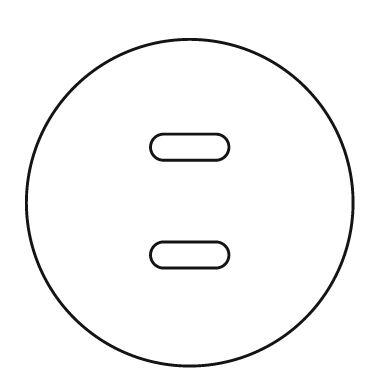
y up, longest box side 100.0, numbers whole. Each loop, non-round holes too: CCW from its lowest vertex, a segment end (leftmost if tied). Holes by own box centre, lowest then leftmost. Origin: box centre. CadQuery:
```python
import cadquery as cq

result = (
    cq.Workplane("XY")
    .moveTo(0.0, 0.0)
    .circle(50.0)
    .moveTo(-8.0, -20.0)
    .lineTo(8.0, -20.0)
    .threePointArc((12.0, -16.0), (8.0, -12.0))
    .lineTo(-8.0, -12.0)
    .threePointArc((-12.0, -16.0), (-8.0, -20.0))
    .close()
    .moveTo(-8.0, 13.0)
    .lineTo(8.0, 13.0)
    .threePointArc((12.0, 17.0), (8.0, 21.0))
    .lineTo(-8.0, 21.0)
    .threePointArc((-12.0, 17.0), (-8.0, 13.0))
    .close()
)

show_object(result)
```